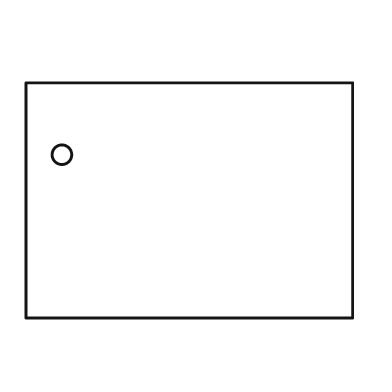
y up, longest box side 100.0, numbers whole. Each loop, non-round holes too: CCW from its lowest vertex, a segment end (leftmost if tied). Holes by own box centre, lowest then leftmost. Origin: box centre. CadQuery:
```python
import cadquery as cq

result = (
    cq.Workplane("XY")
    .moveTo(-50.0, -36.0)
    .lineTo(50.0, -36.0)
    .lineTo(50.0, 36.0)
    .lineTo(-50.0, 36.0)
    .close()
    .moveTo(-39.0, 14.0)
    .circle(3.0)
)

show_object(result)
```